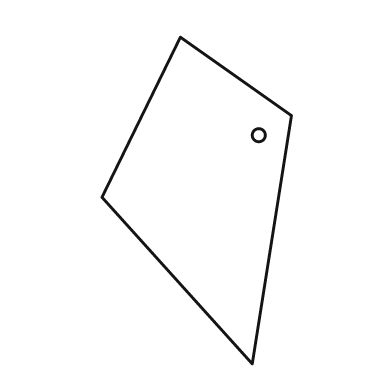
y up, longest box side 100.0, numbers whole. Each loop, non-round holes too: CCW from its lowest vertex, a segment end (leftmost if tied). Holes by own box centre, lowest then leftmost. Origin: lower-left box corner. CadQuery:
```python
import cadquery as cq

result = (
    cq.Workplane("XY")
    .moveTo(46.0, 0.0)
    .lineTo(58.0, 76.0)
    .lineTo(24.0, 100.0)
    .lineTo(0.0, 51.0)
    .close()
    .moveTo(48.0, 70.0)
    .circle(2.0)
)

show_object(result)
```